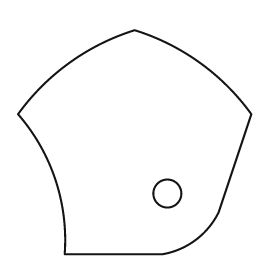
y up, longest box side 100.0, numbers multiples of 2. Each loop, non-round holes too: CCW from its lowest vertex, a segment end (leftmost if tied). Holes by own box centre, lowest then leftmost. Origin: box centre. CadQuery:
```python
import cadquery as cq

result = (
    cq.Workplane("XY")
    .moveTo(-30.0, -48.0)
    .lineTo(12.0, -48.0)
    .threePointArc((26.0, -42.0), (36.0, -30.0))
    .lineTo(50.0, 12.0)
    .threePointArc((28.0, 34.0), (0.0, 48.0))
    .threePointArc((-28.0, 34.0), (-50.0, 12.0))
    .threePointArc((-34.0, -16.0), (-30.0, -48.0))
    .close()
    .moveTo(14.0, -22.0)
    .circle(6.0)
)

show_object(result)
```